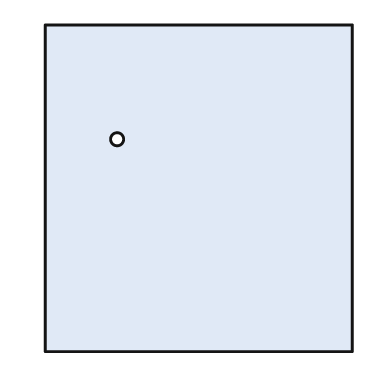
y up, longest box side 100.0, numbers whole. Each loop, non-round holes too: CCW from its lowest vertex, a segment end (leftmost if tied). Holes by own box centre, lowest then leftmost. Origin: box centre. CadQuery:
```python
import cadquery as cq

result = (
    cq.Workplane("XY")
    .moveTo(-47.0, -50.0)
    .lineTo(47.0, -50.0)
    .lineTo(47.0, 50.0)
    .lineTo(-47.0, 50.0)
    .close()
    .moveTo(-25.0, 15.0)
    .circle(2.0)
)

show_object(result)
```